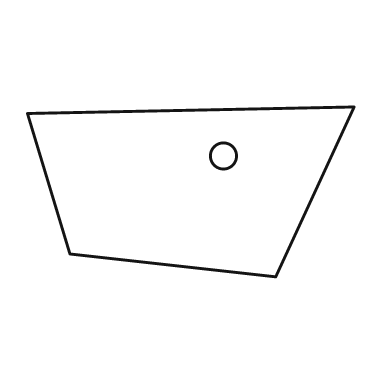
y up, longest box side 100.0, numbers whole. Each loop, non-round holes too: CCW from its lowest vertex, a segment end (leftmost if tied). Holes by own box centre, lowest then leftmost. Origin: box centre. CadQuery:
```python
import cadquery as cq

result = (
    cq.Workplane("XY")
    .moveTo(26.0, -26.0)
    .lineTo(50.0, 26.0)
    .lineTo(-50.0, 24.0)
    .lineTo(-37.0, -19.0)
    .close()
    .moveTo(10.0, 11.0)
    .circle(4.0)
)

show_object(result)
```